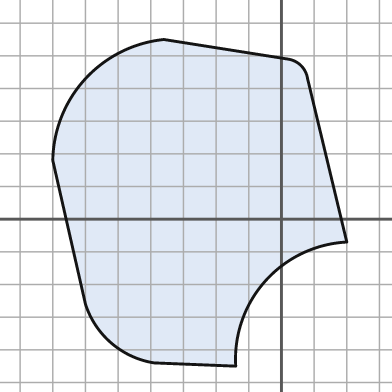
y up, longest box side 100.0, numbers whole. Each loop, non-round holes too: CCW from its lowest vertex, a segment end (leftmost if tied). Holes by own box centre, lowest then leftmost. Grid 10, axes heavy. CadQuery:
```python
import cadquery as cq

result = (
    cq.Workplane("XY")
    .moveTo(-14.0, -45.0)
    .threePointArc((-5.0, -19.0), (20.0, -7.0))
    .lineTo(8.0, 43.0)
    .threePointArc((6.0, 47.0), (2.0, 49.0))
    .lineTo(-36.0, 55.0)
    .threePointArc((-60.0, 43.0), (-70.0, 18.0))
    .lineTo(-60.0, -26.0)
    .threePointArc((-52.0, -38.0), (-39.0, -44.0))
    .close()
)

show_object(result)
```